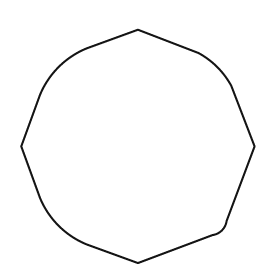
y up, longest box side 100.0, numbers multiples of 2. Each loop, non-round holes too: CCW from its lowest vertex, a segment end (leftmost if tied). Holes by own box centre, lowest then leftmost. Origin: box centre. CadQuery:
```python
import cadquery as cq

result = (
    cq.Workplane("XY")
    .moveTo(0.0, -50.0)
    .lineTo(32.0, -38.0)
    .threePointArc((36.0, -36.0), (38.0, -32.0))
    .lineTo(50.0, 0.0)
    .lineTo(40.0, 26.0)
    .threePointArc((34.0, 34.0), (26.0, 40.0))
    .lineTo(0.0, 50.0)
    .lineTo(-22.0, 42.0)
    .threePointArc((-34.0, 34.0), (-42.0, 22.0))
    .lineTo(-50.0, 0.0)
    .lineTo(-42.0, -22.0)
    .threePointArc((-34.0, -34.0), (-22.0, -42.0))
    .close()
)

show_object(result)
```